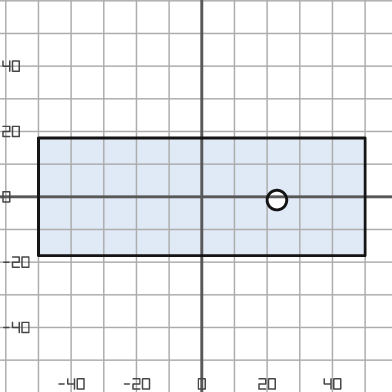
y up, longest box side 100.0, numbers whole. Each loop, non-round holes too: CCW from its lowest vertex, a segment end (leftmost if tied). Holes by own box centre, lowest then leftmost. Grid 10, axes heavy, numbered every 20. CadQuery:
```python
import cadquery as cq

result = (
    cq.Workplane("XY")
    .moveTo(-50.0, -18.0)
    .lineTo(50.0, -18.0)
    .lineTo(50.0, 18.0)
    .lineTo(-50.0, 18.0)
    .close()
    .moveTo(23.0, -1.0)
    .circle(3.0)
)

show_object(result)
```